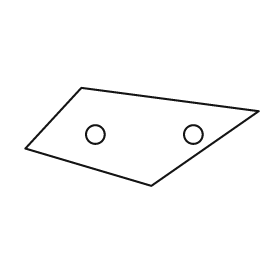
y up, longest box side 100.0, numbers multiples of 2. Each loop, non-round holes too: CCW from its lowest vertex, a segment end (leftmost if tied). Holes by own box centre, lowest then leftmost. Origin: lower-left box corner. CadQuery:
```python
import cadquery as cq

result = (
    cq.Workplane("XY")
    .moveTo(54.0, 0.0)
    .lineTo(100.0, 32.0)
    .lineTo(24.0, 42.0)
    .lineTo(0.0, 16.0)
    .close()
    .moveTo(30.0, 22.0)
    .circle(4.0)
    .moveTo(72.0, 22.0)
    .circle(4.0)
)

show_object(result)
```